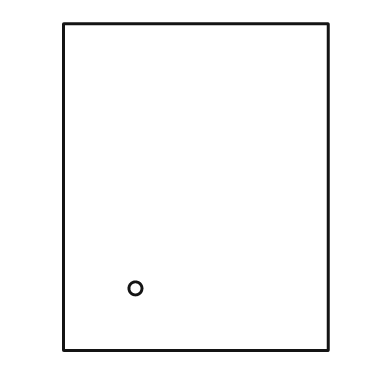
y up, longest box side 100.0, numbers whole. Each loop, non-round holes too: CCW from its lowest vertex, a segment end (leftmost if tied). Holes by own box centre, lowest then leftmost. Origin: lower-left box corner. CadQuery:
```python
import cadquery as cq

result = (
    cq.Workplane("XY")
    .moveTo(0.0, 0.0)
    .lineTo(81.0, 0.0)
    .lineTo(81.0, 100.0)
    .lineTo(0.0, 100.0)
    .close()
    .moveTo(22.0, 19.0)
    .circle(2.0)
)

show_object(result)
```